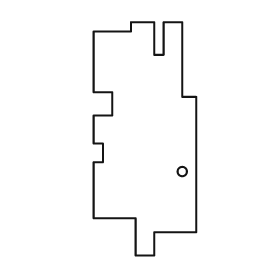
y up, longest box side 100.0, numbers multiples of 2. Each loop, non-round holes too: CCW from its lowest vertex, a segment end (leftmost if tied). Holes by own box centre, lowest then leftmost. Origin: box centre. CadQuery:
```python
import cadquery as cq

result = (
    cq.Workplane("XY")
    .moveTo(-4.0, -50.0)
    .lineTo(4.0, -50.0)
    .lineTo(4.0, -40.0)
    .lineTo(22.0, -40.0)
    .lineTo(22.0, 18.0)
    .lineTo(16.0, 18.0)
    .lineTo(16.0, 50.0)
    .lineTo(8.0, 50.0)
    .lineTo(8.0, 36.0)
    .lineTo(4.0, 36.0)
    .lineTo(4.0, 50.0)
    .lineTo(-6.0, 50.0)
    .lineTo(-6.0, 46.0)
    .lineTo(-22.0, 46.0)
    .lineTo(-22.0, 20.0)
    .lineTo(-14.0, 20.0)
    .lineTo(-14.0, 10.0)
    .lineTo(-22.0, 10.0)
    .lineTo(-22.0, -2.0)
    .lineTo(-18.0, -2.0)
    .lineTo(-18.0, -10.0)
    .lineTo(-22.0, -10.0)
    .lineTo(-22.0, -34.0)
    .lineTo(-4.0, -34.0)
    .close()
    .moveTo(16.0, -14.0)
    .circle(2.0)
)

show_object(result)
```